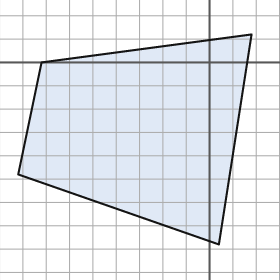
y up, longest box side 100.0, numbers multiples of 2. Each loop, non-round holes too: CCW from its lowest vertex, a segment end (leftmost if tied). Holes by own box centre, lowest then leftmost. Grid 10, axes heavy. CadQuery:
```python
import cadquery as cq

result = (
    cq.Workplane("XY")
    .moveTo(4.0, -78.0)
    .lineTo(18.0, 12.0)
    .lineTo(-72.0, 0.0)
    .lineTo(-82.0, -48.0)
    .close()
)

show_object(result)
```